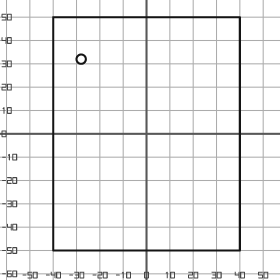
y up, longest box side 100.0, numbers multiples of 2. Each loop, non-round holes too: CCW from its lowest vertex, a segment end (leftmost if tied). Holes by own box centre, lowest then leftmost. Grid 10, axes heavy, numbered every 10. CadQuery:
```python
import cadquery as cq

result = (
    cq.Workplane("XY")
    .moveTo(-40.0, -50.0)
    .lineTo(40.0, -50.0)
    .lineTo(40.0, 50.0)
    .lineTo(-40.0, 50.0)
    .close()
    .moveTo(-28.0, 32.0)
    .circle(2.0)
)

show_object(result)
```